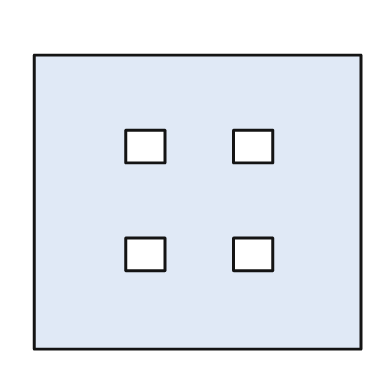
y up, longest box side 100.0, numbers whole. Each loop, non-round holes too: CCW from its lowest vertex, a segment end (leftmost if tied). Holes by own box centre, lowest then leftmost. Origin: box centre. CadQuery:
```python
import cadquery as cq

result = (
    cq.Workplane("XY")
    .moveTo(-50.0, -45.0)
    .lineTo(50.0, -45.0)
    .lineTo(50.0, 45.0)
    .lineTo(-50.0, 45.0)
    .close()
    .moveTo(-22.0, -21.0)
    .lineTo(-10.0, -21.0)
    .lineTo(-10.0, -11.0)
    .lineTo(-22.0, -11.0)
    .close()
    .moveTo(11.0, -21.0)
    .lineTo(23.0, -21.0)
    .lineTo(23.0, -11.0)
    .lineTo(11.0, -11.0)
    .close()
    .moveTo(-22.0, 12.0)
    .lineTo(-10.0, 12.0)
    .lineTo(-10.0, 22.0)
    .lineTo(-22.0, 22.0)
    .close()
    .moveTo(11.0, 12.0)
    .lineTo(23.0, 12.0)
    .lineTo(23.0, 22.0)
    .lineTo(11.0, 22.0)
    .close()
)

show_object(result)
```